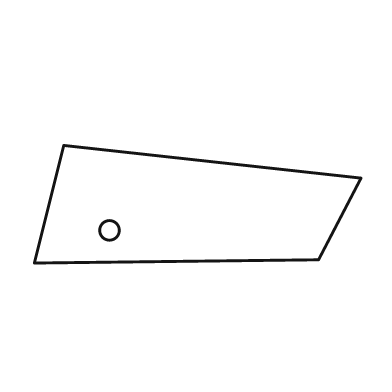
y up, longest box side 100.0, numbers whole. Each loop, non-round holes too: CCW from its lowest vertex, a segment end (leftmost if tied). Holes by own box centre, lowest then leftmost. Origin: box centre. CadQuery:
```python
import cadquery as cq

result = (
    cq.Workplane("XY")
    .moveTo(-50.0, -18.0)
    .lineTo(37.0, -17.0)
    .lineTo(50.0, 8.0)
    .lineTo(-41.0, 18.0)
    .close()
    .moveTo(-27.0, -8.0)
    .circle(3.0)
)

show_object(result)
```